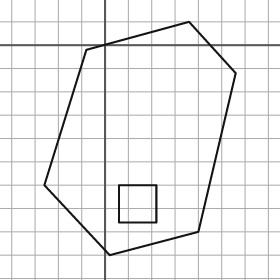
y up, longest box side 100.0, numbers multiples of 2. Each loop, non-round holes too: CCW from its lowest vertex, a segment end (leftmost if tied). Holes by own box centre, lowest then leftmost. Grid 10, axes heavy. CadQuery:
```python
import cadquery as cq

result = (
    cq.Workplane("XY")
    .moveTo(2.0, -90.0)
    .lineTo(40.0, -80.0)
    .lineTo(56.0, -12.0)
    .lineTo(36.0, 10.0)
    .lineTo(-8.0, -2.0)
    .lineTo(-26.0, -60.0)
    .close()
    .moveTo(6.0, -76.0)
    .lineTo(22.0, -76.0)
    .lineTo(22.0, -60.0)
    .lineTo(6.0, -60.0)
    .close()
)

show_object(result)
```